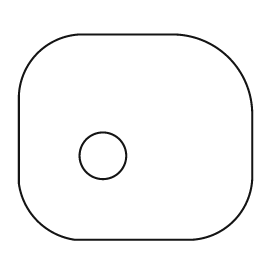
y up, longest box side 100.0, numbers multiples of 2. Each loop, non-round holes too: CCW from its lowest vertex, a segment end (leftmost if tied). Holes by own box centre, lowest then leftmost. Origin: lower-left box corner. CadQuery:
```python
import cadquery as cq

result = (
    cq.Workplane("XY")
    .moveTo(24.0, 0.0)
    .lineTo(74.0, 0.0)
    .threePointArc((92.0, 8.0), (100.0, 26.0))
    .lineTo(100.0, 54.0)
    .threePointArc((90.0, 78.0), (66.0, 88.0))
    .lineTo(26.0, 88.0)
    .threePointArc((8.0, 80.0), (0.0, 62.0))
    .lineTo(0.0, 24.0)
    .threePointArc((8.0, 8.0), (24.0, 0.0))
    .close()
    .moveTo(36.0, 36.0)
    .circle(10.0)
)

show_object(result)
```